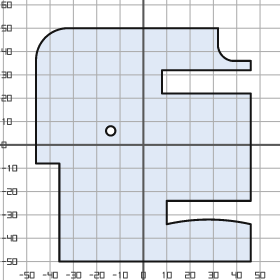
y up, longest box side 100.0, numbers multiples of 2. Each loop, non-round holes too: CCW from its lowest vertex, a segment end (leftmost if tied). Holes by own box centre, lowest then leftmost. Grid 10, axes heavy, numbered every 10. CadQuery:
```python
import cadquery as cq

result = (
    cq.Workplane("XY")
    .moveTo(-36.0, -50.0)
    .lineTo(46.0, -50.0)
    .lineTo(46.0, -34.0)
    .threePointArc((28.0, -32.0), (10.0, -34.0))
    .lineTo(10.0, -24.0)
    .lineTo(46.0, -24.0)
    .lineTo(46.0, 22.0)
    .lineTo(8.0, 22.0)
    .lineTo(8.0, 32.0)
    .lineTo(46.0, 32.0)
    .lineTo(46.0, 36.0)
    .lineTo(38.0, 36.0)
    .threePointArc((34.0, 38.0), (32.0, 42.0))
    .lineTo(32.0, 50.0)
    .lineTo(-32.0, 50.0)
    .threePointArc((-42.0, 46.0), (-46.0, 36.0))
    .lineTo(-46.0, -8.0)
    .lineTo(-36.0, -8.0)
    .close()
    .moveTo(-14.0, 6.0)
    .circle(2.0)
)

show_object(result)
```